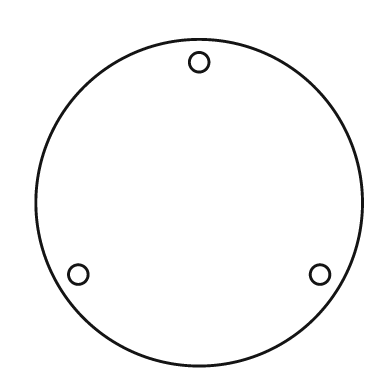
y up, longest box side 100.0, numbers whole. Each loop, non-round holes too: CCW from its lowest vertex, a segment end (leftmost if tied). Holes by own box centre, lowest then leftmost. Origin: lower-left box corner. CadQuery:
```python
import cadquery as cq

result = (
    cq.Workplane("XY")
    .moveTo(50.0, 50.0)
    .circle(50.0)
    .moveTo(13.0, 28.0)
    .circle(3.0)
    .moveTo(87.0, 28.0)
    .circle(3.0)
    .moveTo(50.0, 93.0)
    .circle(3.0)
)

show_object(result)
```